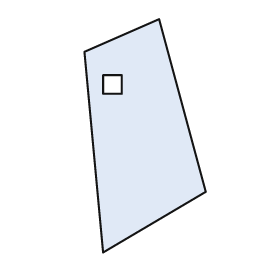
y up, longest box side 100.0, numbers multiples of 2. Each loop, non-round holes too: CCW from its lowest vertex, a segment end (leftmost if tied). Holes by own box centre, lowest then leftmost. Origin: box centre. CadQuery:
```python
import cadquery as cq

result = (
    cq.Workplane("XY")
    .moveTo(-18.0, -50.0)
    .lineTo(26.0, -24.0)
    .lineTo(6.0, 50.0)
    .lineTo(-26.0, 36.0)
    .close()
    .moveTo(-18.0, 18.0)
    .lineTo(-10.0, 18.0)
    .lineTo(-10.0, 26.0)
    .lineTo(-18.0, 26.0)
    .close()
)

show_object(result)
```